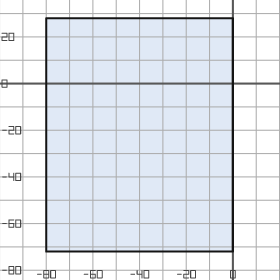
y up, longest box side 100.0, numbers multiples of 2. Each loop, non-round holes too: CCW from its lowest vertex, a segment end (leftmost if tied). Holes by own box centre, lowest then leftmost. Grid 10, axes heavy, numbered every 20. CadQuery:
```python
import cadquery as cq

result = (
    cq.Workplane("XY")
    .moveTo(-80.0, -72.0)
    .lineTo(0.0, -72.0)
    .lineTo(0.0, 28.0)
    .lineTo(-80.0, 28.0)
    .close()
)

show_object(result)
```